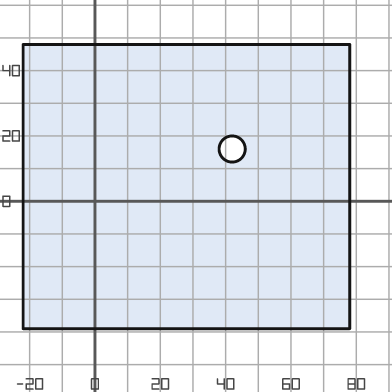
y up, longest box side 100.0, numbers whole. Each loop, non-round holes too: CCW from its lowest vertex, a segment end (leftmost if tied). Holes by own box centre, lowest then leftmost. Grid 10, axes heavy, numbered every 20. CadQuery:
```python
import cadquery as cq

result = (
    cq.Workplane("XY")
    .moveTo(-22.0, -39.0)
    .lineTo(78.0, -39.0)
    .lineTo(78.0, 48.0)
    .lineTo(-22.0, 48.0)
    .close()
    .moveTo(42.0, 16.0)
    .circle(4.0)
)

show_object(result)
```